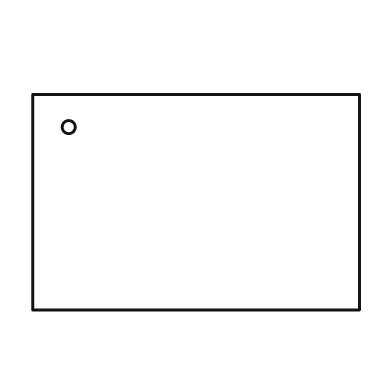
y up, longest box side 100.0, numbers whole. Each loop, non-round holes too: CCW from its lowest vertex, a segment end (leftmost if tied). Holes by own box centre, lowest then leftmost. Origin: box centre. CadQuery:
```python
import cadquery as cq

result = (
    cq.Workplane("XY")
    .moveTo(-50.0, -33.0)
    .lineTo(50.0, -33.0)
    .lineTo(50.0, 33.0)
    .lineTo(-50.0, 33.0)
    .close()
    .moveTo(-39.0, 23.0)
    .circle(2.0)
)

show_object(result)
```